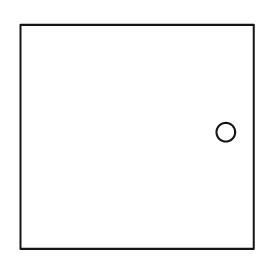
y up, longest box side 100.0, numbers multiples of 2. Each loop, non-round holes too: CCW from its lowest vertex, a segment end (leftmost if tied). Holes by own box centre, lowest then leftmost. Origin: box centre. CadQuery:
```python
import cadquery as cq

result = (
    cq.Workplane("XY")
    .moveTo(-50.0, -48.0)
    .lineTo(50.0, -48.0)
    .lineTo(50.0, 48.0)
    .lineTo(-50.0, 48.0)
    .close()
    .moveTo(38.0, 2.0)
    .circle(4.0)
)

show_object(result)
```